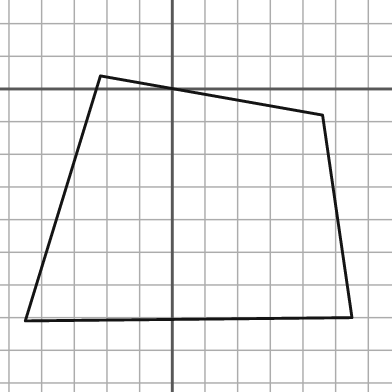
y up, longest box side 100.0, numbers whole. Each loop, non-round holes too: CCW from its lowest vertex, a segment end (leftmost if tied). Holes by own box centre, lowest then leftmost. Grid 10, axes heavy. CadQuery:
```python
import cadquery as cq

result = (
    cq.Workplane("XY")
    .moveTo(-45.0, -71.0)
    .lineTo(55.0, -70.0)
    .lineTo(46.0, -8.0)
    .lineTo(-22.0, 4.0)
    .close()
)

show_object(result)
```